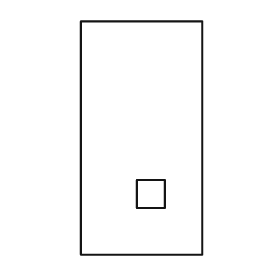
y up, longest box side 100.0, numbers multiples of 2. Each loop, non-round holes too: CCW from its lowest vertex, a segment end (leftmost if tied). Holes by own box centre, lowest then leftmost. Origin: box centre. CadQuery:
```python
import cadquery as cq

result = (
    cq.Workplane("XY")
    .moveTo(-26.0, -50.0)
    .lineTo(26.0, -50.0)
    .lineTo(26.0, 50.0)
    .lineTo(-26.0, 50.0)
    .close()
    .moveTo(-2.0, -30.0)
    .lineTo(10.0, -30.0)
    .lineTo(10.0, -18.0)
    .lineTo(-2.0, -18.0)
    .close()
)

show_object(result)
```